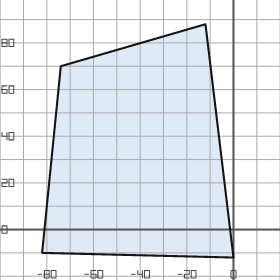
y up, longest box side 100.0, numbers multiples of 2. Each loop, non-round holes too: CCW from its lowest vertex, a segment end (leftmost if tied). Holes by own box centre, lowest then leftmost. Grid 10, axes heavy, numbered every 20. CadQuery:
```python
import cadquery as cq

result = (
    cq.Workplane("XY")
    .moveTo(0.0, -12.0)
    .lineTo(-12.0, 88.0)
    .lineTo(-74.0, 70.0)
    .lineTo(-82.0, -10.0)
    .close()
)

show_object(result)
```